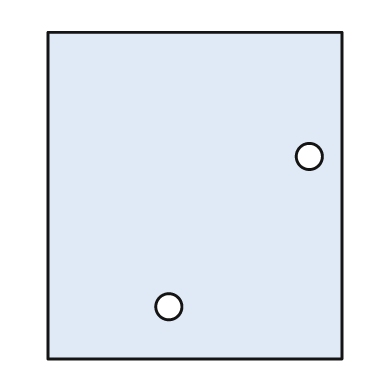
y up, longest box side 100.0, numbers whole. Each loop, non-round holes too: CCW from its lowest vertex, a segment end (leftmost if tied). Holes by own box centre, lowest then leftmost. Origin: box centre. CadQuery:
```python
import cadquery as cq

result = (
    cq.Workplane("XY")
    .moveTo(-45.0, -50.0)
    .lineTo(45.0, -50.0)
    .lineTo(45.0, 50.0)
    .lineTo(-45.0, 50.0)
    .close()
    .moveTo(-8.0, -34.0)
    .circle(4.0)
    .moveTo(35.0, 12.0)
    .circle(4.0)
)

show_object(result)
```